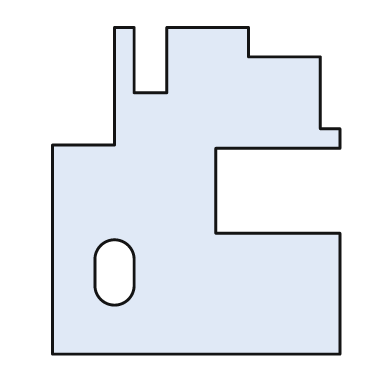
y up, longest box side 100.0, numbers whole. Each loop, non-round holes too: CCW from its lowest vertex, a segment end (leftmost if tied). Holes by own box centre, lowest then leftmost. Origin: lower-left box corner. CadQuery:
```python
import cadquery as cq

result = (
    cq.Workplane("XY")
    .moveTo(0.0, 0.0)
    .lineTo(88.0, 0.0)
    .lineTo(88.0, 37.0)
    .lineTo(50.0, 37.0)
    .lineTo(50.0, 63.0)
    .lineTo(88.0, 63.0)
    .lineTo(88.0, 69.0)
    .lineTo(82.0, 69.0)
    .lineTo(82.0, 91.0)
    .lineTo(60.0, 91.0)
    .lineTo(60.0, 100.0)
    .lineTo(35.0, 100.0)
    .lineTo(35.0, 80.0)
    .lineTo(25.0, 80.0)
    .lineTo(25.0, 100.0)
    .lineTo(19.0, 100.0)
    .lineTo(19.0, 64.0)
    .lineTo(0.0, 64.0)
    .close()
    .moveTo(13.0, 21.0)
    .threePointArc((19.0, 15.0), (25.0, 21.0))
    .lineTo(25.0, 29.0)
    .threePointArc((19.0, 35.0), (13.0, 29.0))
    .close()
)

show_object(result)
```